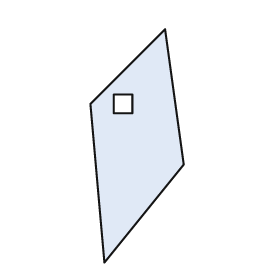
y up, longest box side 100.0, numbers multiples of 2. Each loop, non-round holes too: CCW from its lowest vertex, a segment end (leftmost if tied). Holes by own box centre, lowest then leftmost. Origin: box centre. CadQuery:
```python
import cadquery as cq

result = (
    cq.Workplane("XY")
    .moveTo(-14.0, -50.0)
    .lineTo(20.0, -8.0)
    .lineTo(12.0, 50.0)
    .lineTo(-20.0, 18.0)
    .close()
    .moveTo(-10.0, 14.0)
    .lineTo(-2.0, 14.0)
    .lineTo(-2.0, 22.0)
    .lineTo(-10.0, 22.0)
    .close()
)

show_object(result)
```